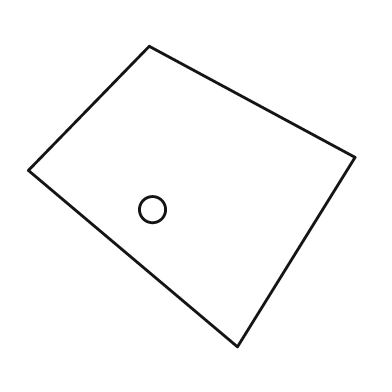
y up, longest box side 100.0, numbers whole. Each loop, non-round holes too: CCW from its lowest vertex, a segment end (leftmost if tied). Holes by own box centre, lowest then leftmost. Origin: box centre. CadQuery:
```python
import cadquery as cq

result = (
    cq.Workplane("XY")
    .moveTo(14.0, -46.0)
    .lineTo(50.0, 12.0)
    .lineTo(-13.0, 46.0)
    .lineTo(-50.0, 8.0)
    .close()
    .moveTo(-12.0, -4.0)
    .circle(4.0)
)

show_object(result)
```